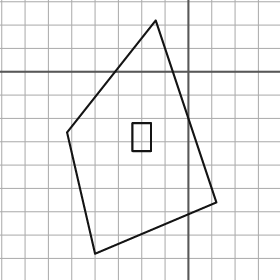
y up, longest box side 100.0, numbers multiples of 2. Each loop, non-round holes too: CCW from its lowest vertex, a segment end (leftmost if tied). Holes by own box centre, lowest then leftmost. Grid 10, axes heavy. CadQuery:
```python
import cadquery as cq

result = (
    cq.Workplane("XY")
    .moveTo(-40.0, -78.0)
    .lineTo(12.0, -56.0)
    .lineTo(-14.0, 22.0)
    .lineTo(-52.0, -26.0)
    .close()
    .moveTo(-24.0, -34.0)
    .lineTo(-16.0, -34.0)
    .lineTo(-16.0, -22.0)
    .lineTo(-24.0, -22.0)
    .close()
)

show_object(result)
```